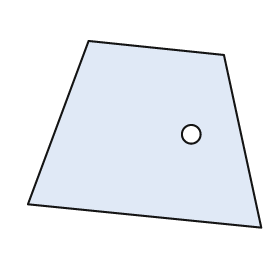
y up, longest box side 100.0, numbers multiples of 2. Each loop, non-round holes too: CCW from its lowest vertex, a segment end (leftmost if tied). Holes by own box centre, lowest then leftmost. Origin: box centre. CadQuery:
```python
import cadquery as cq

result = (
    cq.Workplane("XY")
    .moveTo(50.0, -40.0)
    .lineTo(34.0, 34.0)
    .lineTo(-24.0, 40.0)
    .lineTo(-50.0, -30.0)
    .close()
    .moveTo(20.0, 0.0)
    .circle(4.0)
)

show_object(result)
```